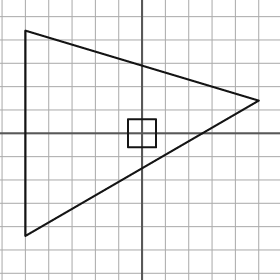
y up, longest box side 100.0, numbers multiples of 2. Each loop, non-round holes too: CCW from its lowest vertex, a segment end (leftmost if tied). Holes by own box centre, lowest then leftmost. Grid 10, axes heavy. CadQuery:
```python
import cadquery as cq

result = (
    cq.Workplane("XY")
    .moveTo(-50.0, -44.0)
    .lineTo(50.0, 14.0)
    .lineTo(-50.0, 44.0)
    .close()
    .moveTo(-6.0, -6.0)
    .lineTo(6.0, -6.0)
    .lineTo(6.0, 6.0)
    .lineTo(-6.0, 6.0)
    .close()
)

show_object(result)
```